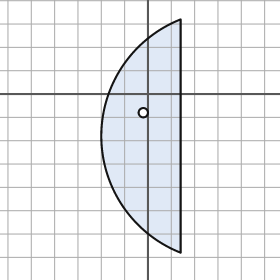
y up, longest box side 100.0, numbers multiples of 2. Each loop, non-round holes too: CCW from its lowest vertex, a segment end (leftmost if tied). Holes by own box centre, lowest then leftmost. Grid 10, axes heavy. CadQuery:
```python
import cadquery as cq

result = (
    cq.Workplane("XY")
    .moveTo(14.0, -68.0)
    .lineTo(14.0, 32.0)
    .threePointArc((-20.0, -18.0), (14.0, -68.0))
    .close()
    .moveTo(-2.0, -8.0)
    .circle(2.0)
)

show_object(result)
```